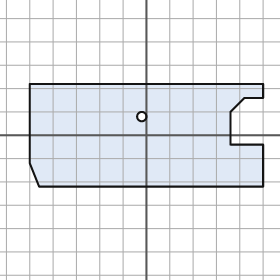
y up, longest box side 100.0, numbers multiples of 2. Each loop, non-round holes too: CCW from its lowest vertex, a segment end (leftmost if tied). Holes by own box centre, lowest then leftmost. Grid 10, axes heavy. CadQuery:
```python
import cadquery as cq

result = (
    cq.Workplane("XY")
    .moveTo(-46.0, -22.0)
    .lineTo(50.0, -22.0)
    .lineTo(50.0, -4.0)
    .lineTo(36.0, -4.0)
    .lineTo(36.0, 10.0)
    .lineTo(42.0, 16.0)
    .lineTo(50.0, 16.0)
    .lineTo(50.0, 22.0)
    .lineTo(-50.0, 22.0)
    .lineTo(-50.0, -12.0)
    .close()
    .moveTo(-2.0, 8.0)
    .circle(2.0)
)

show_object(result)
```